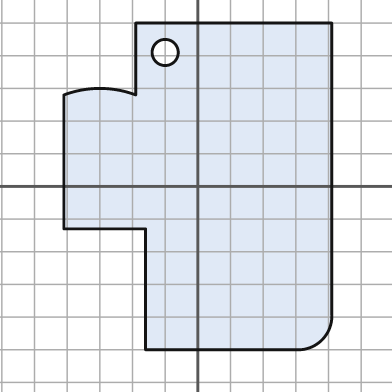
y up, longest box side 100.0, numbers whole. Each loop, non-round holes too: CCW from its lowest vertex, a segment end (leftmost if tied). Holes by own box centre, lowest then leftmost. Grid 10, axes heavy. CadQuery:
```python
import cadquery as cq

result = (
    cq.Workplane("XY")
    .moveTo(-16.0, -50.0)
    .lineTo(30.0, -50.0)
    .threePointArc((38.0, -47.0), (41.0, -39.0))
    .lineTo(41.0, 50.0)
    .lineTo(-19.0, 50.0)
    .lineTo(-19.0, 28.0)
    .threePointArc((-30.0, 30.0), (-41.0, 28.0))
    .lineTo(-41.0, -13.0)
    .lineTo(-16.0, -13.0)
    .close()
    .moveTo(-10.0, 41.0)
    .circle(4.0)
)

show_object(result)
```